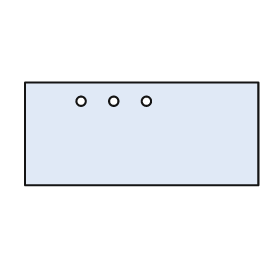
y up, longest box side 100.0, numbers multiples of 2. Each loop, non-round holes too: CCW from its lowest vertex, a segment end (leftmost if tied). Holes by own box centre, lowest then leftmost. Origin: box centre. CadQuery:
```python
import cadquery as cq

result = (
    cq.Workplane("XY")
    .moveTo(-50.0, -22.0)
    .lineTo(50.0, -22.0)
    .lineTo(50.0, 22.0)
    .lineTo(-50.0, 22.0)
    .close()
    .moveTo(-26.0, 14.0)
    .circle(2.0)
    .moveTo(-12.0, 14.0)
    .circle(2.0)
    .moveTo(2.0, 14.0)
    .circle(2.0)
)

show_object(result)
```